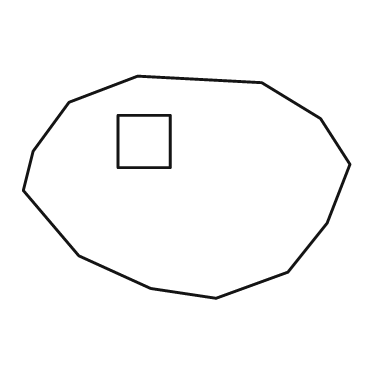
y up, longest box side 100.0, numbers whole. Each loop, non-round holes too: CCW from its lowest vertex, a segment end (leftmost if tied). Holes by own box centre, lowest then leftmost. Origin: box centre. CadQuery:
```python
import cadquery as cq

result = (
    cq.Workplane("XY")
    .moveTo(9.0, -34.0)
    .lineTo(31.0, -26.0)
    .lineTo(43.0, -11.0)
    .lineTo(50.0, 7.0)
    .lineTo(41.0, 21.0)
    .lineTo(23.0, 32.0)
    .lineTo(-15.0, 34.0)
    .lineTo(-36.0, 26.0)
    .lineTo(-47.0, 11.0)
    .lineTo(-50.0, -1.0)
    .lineTo(-33.0, -21.0)
    .lineTo(-11.0, -31.0)
    .close()
    .moveTo(-21.0, 6.0)
    .lineTo(-5.0, 6.0)
    .lineTo(-5.0, 22.0)
    .lineTo(-21.0, 22.0)
    .close()
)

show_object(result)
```